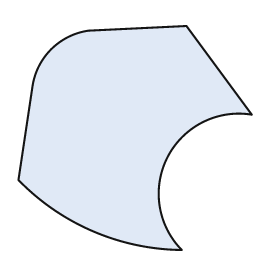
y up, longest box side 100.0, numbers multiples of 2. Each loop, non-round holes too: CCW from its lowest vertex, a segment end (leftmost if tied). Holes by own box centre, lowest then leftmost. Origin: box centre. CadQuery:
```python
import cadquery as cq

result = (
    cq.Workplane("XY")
    .moveTo(20.0, -48.0)
    .threePointArc((14.0, -8.0), (50.0, 10.0))
    .lineTo(22.0, 48.0)
    .lineTo(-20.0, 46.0)
    .threePointArc((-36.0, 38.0), (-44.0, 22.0))
    .lineTo(-50.0, -18.0)
    .threePointArc((-18.0, -40.0), (20.0, -48.0))
    .close()
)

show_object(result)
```